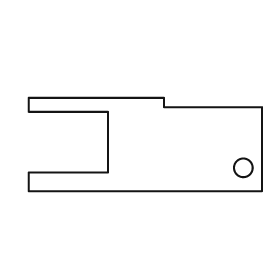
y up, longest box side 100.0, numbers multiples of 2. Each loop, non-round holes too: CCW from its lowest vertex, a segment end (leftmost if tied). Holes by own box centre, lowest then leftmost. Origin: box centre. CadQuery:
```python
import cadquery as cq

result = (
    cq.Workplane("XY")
    .moveTo(-50.0, -20.0)
    .lineTo(50.0, -20.0)
    .lineTo(50.0, 16.0)
    .lineTo(8.0, 16.0)
    .lineTo(8.0, 20.0)
    .lineTo(-50.0, 20.0)
    .lineTo(-50.0, 14.0)
    .lineTo(-16.0, 14.0)
    .lineTo(-16.0, -12.0)
    .lineTo(-50.0, -12.0)
    .close()
    .moveTo(42.0, -10.0)
    .circle(4.0)
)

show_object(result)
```